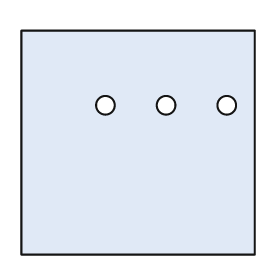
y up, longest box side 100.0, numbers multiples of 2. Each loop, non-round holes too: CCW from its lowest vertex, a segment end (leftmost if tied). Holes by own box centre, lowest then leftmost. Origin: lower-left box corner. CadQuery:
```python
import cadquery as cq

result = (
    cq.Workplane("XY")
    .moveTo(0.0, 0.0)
    .lineTo(100.0, 0.0)
    .lineTo(100.0, 96.0)
    .lineTo(0.0, 96.0)
    .close()
    .moveTo(36.0, 64.0)
    .circle(4.0)
    .moveTo(62.0, 64.0)
    .circle(4.0)
    .moveTo(88.0, 64.0)
    .circle(4.0)
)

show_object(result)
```